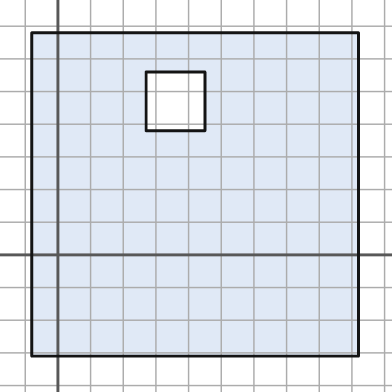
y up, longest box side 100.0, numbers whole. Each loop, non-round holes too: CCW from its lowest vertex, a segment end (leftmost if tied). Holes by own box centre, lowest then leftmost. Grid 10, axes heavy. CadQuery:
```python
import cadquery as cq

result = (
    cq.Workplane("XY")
    .moveTo(-8.0, -31.0)
    .lineTo(92.0, -31.0)
    .lineTo(92.0, 68.0)
    .lineTo(-8.0, 68.0)
    .close()
    .moveTo(27.0, 38.0)
    .lineTo(45.0, 38.0)
    .lineTo(45.0, 56.0)
    .lineTo(27.0, 56.0)
    .close()
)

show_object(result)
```